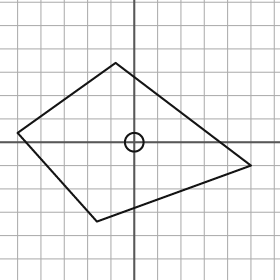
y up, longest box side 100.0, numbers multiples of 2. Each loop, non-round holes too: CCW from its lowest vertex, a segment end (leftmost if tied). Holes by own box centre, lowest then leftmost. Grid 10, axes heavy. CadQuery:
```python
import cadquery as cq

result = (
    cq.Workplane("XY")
    .moveTo(-16.0, -34.0)
    .lineTo(50.0, -10.0)
    .lineTo(-8.0, 34.0)
    .lineTo(-50.0, 4.0)
    .close()
    .moveTo(0.0, 0.0)
    .circle(4.0)
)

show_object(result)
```